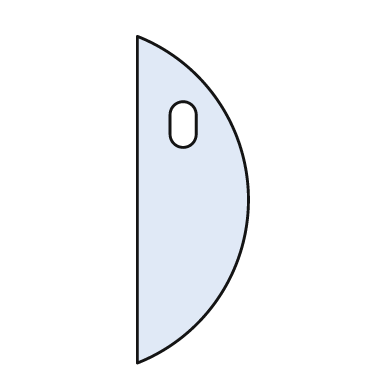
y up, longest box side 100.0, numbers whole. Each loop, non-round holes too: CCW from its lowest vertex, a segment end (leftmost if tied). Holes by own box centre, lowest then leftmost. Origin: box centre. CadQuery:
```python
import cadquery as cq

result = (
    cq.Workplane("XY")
    .moveTo(-17.0, -50.0)
    .threePointArc((17.0, 0.0), (-17.0, 50.0))
    .close()
    .moveTo(-7.0, 20.0)
    .threePointArc((-3.0, 16.0), (1.0, 20.0))
    .lineTo(1.0, 26.0)
    .threePointArc((-3.0, 30.0), (-7.0, 26.0))
    .close()
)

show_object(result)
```